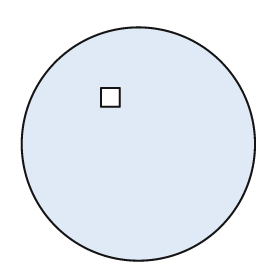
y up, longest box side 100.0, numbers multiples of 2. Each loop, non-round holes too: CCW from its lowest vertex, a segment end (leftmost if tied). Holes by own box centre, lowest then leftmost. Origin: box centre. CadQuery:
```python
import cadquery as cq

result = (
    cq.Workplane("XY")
    .moveTo(0.0, 0.0)
    .circle(50.0)
    .moveTo(-16.0, 16.0)
    .lineTo(-8.0, 16.0)
    .lineTo(-8.0, 24.0)
    .lineTo(-16.0, 24.0)
    .close()
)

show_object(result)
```